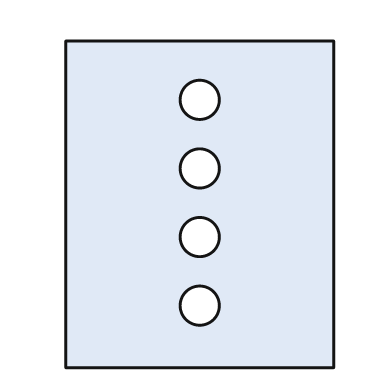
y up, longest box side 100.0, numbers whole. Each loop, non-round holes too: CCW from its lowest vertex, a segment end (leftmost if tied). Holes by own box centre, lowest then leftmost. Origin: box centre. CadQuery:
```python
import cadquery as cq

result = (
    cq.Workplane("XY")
    .moveTo(-41.0, -50.0)
    .lineTo(41.0, -50.0)
    .lineTo(41.0, 50.0)
    .lineTo(-41.0, 50.0)
    .close()
    .moveTo(0.0, -31.0)
    .circle(6.0)
    .moveTo(0.0, -10.0)
    .circle(6.0)
    .moveTo(0.0, 11.0)
    .circle(6.0)
    .moveTo(0.0, 32.0)
    .circle(6.0)
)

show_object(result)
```